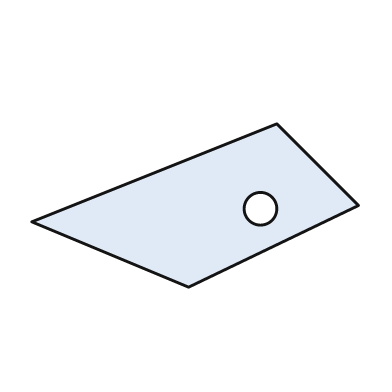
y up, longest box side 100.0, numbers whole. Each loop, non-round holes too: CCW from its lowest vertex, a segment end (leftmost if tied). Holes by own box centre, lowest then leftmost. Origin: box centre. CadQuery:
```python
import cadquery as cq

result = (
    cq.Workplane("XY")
    .moveTo(-2.0, -25.0)
    .lineTo(50.0, 0.0)
    .lineTo(25.0, 25.0)
    .lineTo(-50.0, -5.0)
    .close()
    .moveTo(20.0, -1.0)
    .circle(5.0)
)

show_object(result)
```